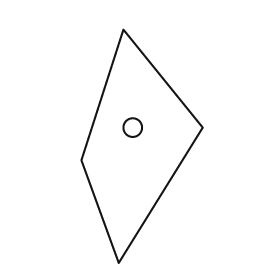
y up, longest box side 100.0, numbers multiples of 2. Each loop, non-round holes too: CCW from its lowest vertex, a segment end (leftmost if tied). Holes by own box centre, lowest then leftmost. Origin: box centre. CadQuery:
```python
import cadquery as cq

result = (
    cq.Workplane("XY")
    .moveTo(-10.0, -50.0)
    .lineTo(26.0, 8.0)
    .lineTo(-8.0, 50.0)
    .lineTo(-26.0, -6.0)
    .close()
    .moveTo(-4.0, 8.0)
    .circle(4.0)
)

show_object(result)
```